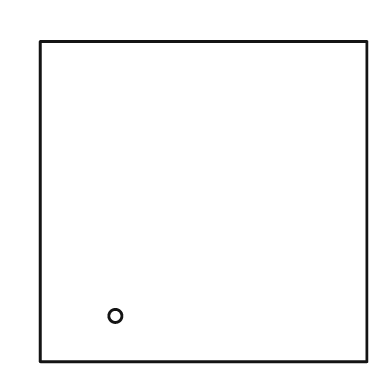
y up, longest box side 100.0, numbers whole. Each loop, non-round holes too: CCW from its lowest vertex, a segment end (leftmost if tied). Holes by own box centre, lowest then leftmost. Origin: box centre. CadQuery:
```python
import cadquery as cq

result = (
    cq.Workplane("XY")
    .moveTo(-50.0, -49.0)
    .lineTo(50.0, -49.0)
    .lineTo(50.0, 49.0)
    .lineTo(-50.0, 49.0)
    .close()
    .moveTo(-27.0, -35.0)
    .circle(2.0)
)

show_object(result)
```